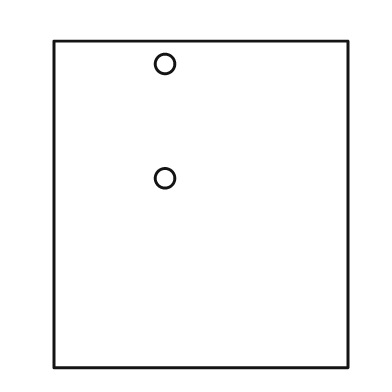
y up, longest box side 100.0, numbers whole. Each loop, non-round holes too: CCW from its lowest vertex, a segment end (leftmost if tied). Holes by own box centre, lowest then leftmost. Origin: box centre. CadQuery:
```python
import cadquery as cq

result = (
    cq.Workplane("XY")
    .moveTo(-45.0, -50.0)
    .lineTo(45.0, -50.0)
    .lineTo(45.0, 50.0)
    .lineTo(-45.0, 50.0)
    .close()
    .moveTo(-11.0, 8.0)
    .circle(3.0)
    .moveTo(-11.0, 43.0)
    .circle(3.0)
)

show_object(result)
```